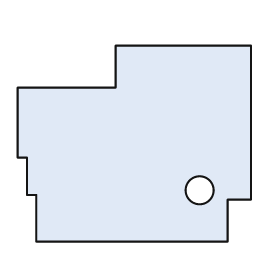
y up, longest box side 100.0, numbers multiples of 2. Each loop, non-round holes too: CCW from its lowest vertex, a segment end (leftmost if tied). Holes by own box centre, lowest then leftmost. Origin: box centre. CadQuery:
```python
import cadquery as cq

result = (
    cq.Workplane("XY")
    .moveTo(-42.0, -42.0)
    .lineTo(40.0, -42.0)
    .lineTo(40.0, -24.0)
    .lineTo(50.0, -24.0)
    .lineTo(50.0, 42.0)
    .lineTo(-8.0, 42.0)
    .lineTo(-8.0, 24.0)
    .lineTo(-50.0, 24.0)
    .lineTo(-50.0, -6.0)
    .lineTo(-46.0, -6.0)
    .lineTo(-46.0, -22.0)
    .lineTo(-42.0, -22.0)
    .close()
    .moveTo(28.0, -20.0)
    .circle(6.0)
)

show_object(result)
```